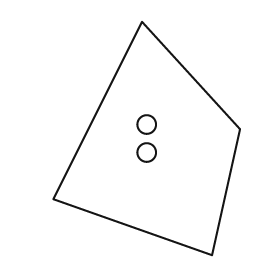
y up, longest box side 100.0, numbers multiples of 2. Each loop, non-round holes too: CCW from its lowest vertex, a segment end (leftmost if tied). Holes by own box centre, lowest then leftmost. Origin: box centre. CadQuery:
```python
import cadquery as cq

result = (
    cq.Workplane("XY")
    .moveTo(28.0, -50.0)
    .lineTo(40.0, 4.0)
    .lineTo(-2.0, 50.0)
    .lineTo(-40.0, -26.0)
    .close()
    .moveTo(0.0, -6.0)
    .circle(4.0)
    .moveTo(0.0, 6.0)
    .circle(4.0)
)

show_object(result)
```